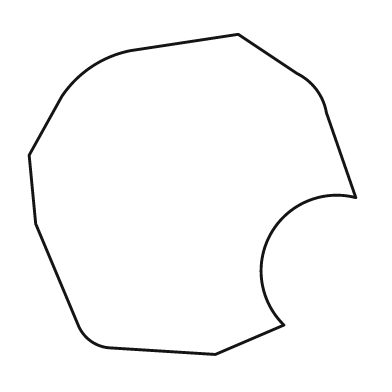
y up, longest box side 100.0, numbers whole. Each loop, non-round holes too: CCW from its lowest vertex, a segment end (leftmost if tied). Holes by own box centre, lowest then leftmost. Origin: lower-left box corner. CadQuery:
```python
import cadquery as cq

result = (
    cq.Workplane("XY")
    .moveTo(57.0, 0.0)
    .lineTo(78.0, 9.0)
    .threePointArc((74.0, 37.0), (100.0, 48.0))
    .lineTo(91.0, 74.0)
    .threePointArc((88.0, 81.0), (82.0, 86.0))
    .lineTo(64.0, 98.0)
    .lineTo(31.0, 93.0)
    .threePointArc((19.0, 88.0), (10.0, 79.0))
    .lineTo(0.0, 61.0)
    .lineTo(2.0, 40.0)
    .lineTo(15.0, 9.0)
    .threePointArc((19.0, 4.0), (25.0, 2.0))
    .close()
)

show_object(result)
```